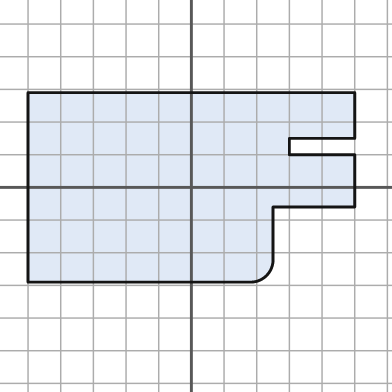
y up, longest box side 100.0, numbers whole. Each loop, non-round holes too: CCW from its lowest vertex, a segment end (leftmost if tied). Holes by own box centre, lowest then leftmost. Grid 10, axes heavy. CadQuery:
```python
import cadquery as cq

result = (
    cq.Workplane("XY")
    .moveTo(-50.0, -29.0)
    .lineTo(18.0, -29.0)
    .threePointArc((23.0, -27.0), (25.0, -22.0))
    .lineTo(25.0, -6.0)
    .lineTo(50.0, -6.0)
    .lineTo(50.0, 10.0)
    .lineTo(30.0, 10.0)
    .lineTo(30.0, 15.0)
    .lineTo(50.0, 15.0)
    .lineTo(50.0, 29.0)
    .lineTo(-50.0, 29.0)
    .close()
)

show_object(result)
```